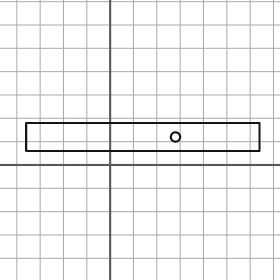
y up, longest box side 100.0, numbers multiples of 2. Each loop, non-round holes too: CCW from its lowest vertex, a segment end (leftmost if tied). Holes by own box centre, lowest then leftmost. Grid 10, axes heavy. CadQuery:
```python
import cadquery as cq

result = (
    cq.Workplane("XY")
    .moveTo(-36.0, 6.0)
    .lineTo(64.0, 6.0)
    .lineTo(64.0, 18.0)
    .lineTo(-36.0, 18.0)
    .close()
    .moveTo(28.0, 12.0)
    .circle(2.0)
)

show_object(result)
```